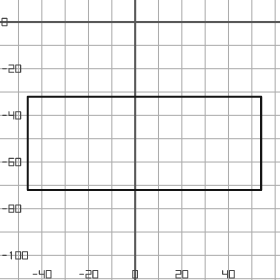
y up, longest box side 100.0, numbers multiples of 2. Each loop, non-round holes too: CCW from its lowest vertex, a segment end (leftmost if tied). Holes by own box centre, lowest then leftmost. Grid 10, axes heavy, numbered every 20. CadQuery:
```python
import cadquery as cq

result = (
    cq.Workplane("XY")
    .moveTo(-46.0, -72.0)
    .lineTo(54.0, -72.0)
    .lineTo(54.0, -32.0)
    .lineTo(-46.0, -32.0)
    .close()
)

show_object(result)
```